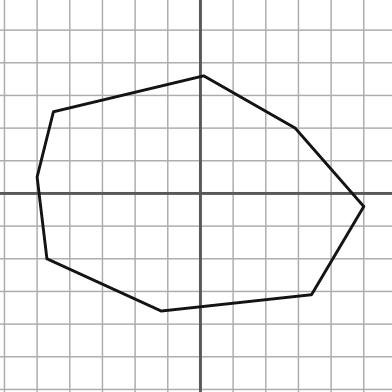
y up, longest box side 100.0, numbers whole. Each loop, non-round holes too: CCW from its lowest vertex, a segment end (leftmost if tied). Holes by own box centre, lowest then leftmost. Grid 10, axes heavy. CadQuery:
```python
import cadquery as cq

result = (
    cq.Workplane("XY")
    .moveTo(-12.0, -36.0)
    .lineTo(34.0, -31.0)
    .lineTo(50.0, -4.0)
    .lineTo(29.0, 20.0)
    .lineTo(1.0, 36.0)
    .lineTo(-45.0, 25.0)
    .lineTo(-50.0, 5.0)
    .lineTo(-47.0, -20.0)
    .close()
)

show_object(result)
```